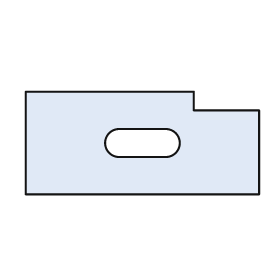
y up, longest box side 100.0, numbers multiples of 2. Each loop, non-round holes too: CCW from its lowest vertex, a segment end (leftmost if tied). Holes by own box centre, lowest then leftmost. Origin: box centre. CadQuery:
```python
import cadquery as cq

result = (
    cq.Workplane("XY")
    .moveTo(-50.0, -22.0)
    .lineTo(50.0, -22.0)
    .lineTo(50.0, 14.0)
    .lineTo(22.0, 14.0)
    .lineTo(22.0, 22.0)
    .lineTo(-50.0, 22.0)
    .close()
    .moveTo(-10.0, -6.0)
    .lineTo(10.0, -6.0)
    .threePointArc((16.0, 0.0), (10.0, 6.0))
    .lineTo(-10.0, 6.0)
    .threePointArc((-16.0, 0.0), (-10.0, -6.0))
    .close()
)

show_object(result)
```